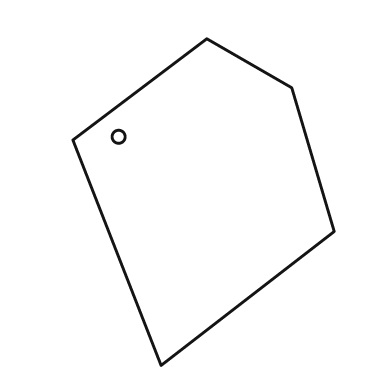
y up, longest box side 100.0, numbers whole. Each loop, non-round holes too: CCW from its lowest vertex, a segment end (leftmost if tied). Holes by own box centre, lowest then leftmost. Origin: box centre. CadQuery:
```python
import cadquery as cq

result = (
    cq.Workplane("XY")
    .moveTo(-13.0, -50.0)
    .lineTo(40.0, -9.0)
    .lineTo(27.0, 35.0)
    .lineTo(1.0, 50.0)
    .lineTo(-40.0, 19.0)
    .close()
    .moveTo(-26.0, 20.0)
    .circle(2.0)
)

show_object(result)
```